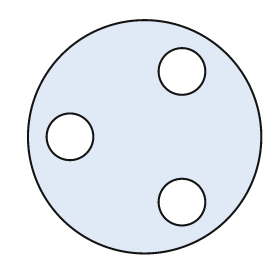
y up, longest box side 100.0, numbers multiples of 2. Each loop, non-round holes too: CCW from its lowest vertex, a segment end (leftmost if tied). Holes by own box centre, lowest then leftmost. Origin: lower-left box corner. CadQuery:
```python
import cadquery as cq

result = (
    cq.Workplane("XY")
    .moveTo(50.0, 50.0)
    .circle(50.0)
    .moveTo(66.0, 22.0)
    .circle(10.0)
    .moveTo(18.0, 50.0)
    .circle(10.0)
    .moveTo(66.0, 78.0)
    .circle(10.0)
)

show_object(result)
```